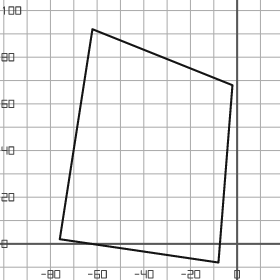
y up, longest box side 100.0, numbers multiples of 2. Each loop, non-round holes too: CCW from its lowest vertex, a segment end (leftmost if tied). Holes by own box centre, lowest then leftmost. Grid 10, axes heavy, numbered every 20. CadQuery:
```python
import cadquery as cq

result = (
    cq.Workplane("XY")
    .moveTo(-8.0, -8.0)
    .lineTo(-2.0, 68.0)
    .lineTo(-62.0, 92.0)
    .lineTo(-76.0, 2.0)
    .close()
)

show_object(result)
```